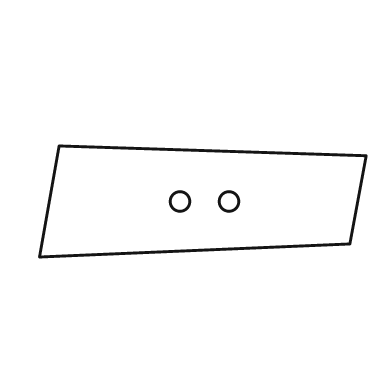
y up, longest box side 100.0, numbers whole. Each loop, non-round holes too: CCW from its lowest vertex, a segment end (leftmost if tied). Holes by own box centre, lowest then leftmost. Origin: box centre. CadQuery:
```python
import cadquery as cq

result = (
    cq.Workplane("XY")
    .moveTo(-50.0, -17.0)
    .lineTo(45.0, -13.0)
    .lineTo(50.0, 14.0)
    .lineTo(-44.0, 17.0)
    .close()
    .moveTo(-7.0, 0.0)
    .circle(3.0)
    .moveTo(8.0, 0.0)
    .circle(3.0)
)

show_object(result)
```